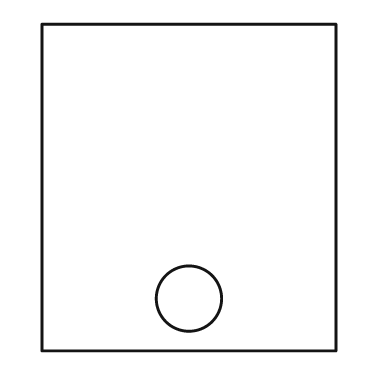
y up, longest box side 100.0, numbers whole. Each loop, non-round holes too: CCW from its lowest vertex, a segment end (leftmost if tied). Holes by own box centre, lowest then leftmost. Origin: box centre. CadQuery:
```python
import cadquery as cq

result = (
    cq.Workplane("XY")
    .moveTo(-45.0, -50.0)
    .lineTo(45.0, -50.0)
    .lineTo(45.0, 50.0)
    .lineTo(-45.0, 50.0)
    .close()
    .moveTo(0.0, -34.0)
    .circle(10.0)
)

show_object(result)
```